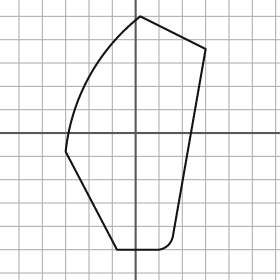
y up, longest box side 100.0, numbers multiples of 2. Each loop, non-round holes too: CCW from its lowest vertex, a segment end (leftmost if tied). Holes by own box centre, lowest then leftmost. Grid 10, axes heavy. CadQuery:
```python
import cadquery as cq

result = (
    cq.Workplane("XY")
    .moveTo(-8.0, -50.0)
    .lineTo(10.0, -50.0)
    .threePointArc((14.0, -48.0), (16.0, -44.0))
    .lineTo(30.0, 36.0)
    .lineTo(2.0, 50.0)
    .threePointArc((-20.0, 24.0), (-30.0, -8.0))
    .close()
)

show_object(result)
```